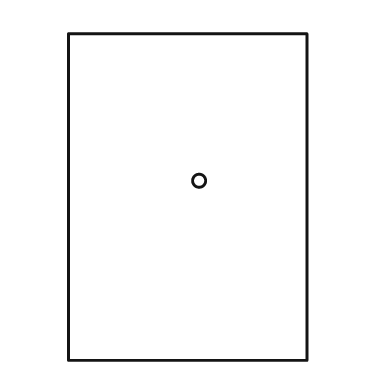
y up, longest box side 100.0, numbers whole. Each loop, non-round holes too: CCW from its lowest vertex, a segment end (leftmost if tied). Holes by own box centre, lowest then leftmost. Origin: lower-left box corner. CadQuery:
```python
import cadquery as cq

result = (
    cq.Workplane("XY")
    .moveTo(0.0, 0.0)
    .lineTo(73.0, 0.0)
    .lineTo(73.0, 100.0)
    .lineTo(0.0, 100.0)
    .close()
    .moveTo(40.0, 55.0)
    .circle(2.0)
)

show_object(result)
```